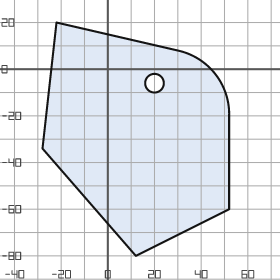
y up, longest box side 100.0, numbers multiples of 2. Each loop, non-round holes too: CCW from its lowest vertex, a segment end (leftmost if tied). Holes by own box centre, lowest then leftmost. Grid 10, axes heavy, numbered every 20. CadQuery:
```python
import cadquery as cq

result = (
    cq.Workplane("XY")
    .moveTo(12.0, -80.0)
    .lineTo(52.0, -60.0)
    .lineTo(52.0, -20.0)
    .threePointArc((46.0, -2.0), (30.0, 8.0))
    .lineTo(-22.0, 20.0)
    .lineTo(-28.0, -34.0)
    .close()
    .moveTo(20.0, -6.0)
    .circle(4.0)
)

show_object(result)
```